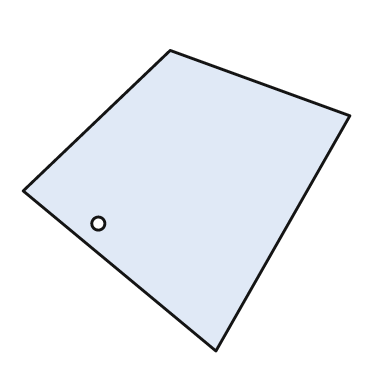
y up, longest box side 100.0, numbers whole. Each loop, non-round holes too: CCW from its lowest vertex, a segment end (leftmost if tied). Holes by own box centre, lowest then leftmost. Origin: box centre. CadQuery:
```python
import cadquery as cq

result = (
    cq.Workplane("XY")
    .moveTo(9.0, -46.0)
    .lineTo(50.0, 26.0)
    .lineTo(-5.0, 46.0)
    .lineTo(-50.0, 3.0)
    .close()
    .moveTo(-27.0, -7.0)
    .circle(2.0)
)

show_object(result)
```